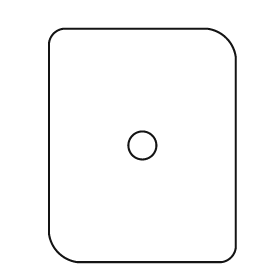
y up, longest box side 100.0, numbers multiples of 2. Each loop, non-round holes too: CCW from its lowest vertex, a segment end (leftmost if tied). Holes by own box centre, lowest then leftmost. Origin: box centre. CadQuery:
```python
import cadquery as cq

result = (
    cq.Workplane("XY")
    .moveTo(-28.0, -50.0)
    .lineTo(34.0, -50.0)
    .threePointArc((38.0, -48.0), (40.0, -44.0))
    .lineTo(40.0, 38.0)
    .threePointArc((36.0, 46.0), (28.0, 50.0))
    .lineTo(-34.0, 50.0)
    .threePointArc((-38.0, 48.0), (-40.0, 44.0))
    .lineTo(-40.0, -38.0)
    .threePointArc((-36.0, -46.0), (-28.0, -50.0))
    .close()
    .moveTo(0.0, 0.0)
    .circle(6.0)
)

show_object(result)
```